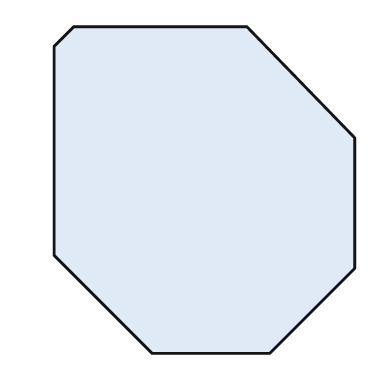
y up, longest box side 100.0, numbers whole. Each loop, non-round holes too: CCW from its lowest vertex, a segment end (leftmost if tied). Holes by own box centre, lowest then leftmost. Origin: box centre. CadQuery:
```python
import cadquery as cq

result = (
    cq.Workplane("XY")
    .moveTo(-16.0, -50.0)
    .lineTo(20.0, -50.0)
    .lineTo(46.0, -24.0)
    .lineTo(46.0, 16.0)
    .lineTo(13.0, 50.0)
    .lineTo(-40.0, 50.0)
    .lineTo(-46.0, 44.0)
    .lineTo(-46.0, -20.0)
    .close()
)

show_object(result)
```